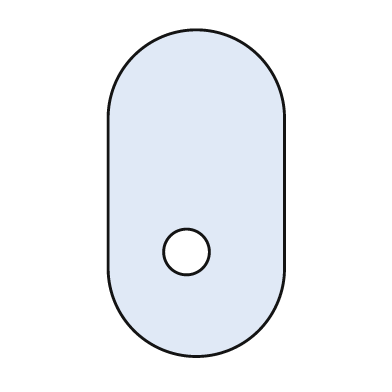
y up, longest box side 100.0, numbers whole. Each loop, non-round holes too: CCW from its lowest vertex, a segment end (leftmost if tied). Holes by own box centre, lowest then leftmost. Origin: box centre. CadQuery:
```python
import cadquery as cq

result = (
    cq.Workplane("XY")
    .moveTo(-27.0, -23.0)
    .threePointArc((0.0, -50.0), (27.0, -23.0))
    .lineTo(27.0, 23.0)
    .threePointArc((0.0, 50.0), (-27.0, 23.0))
    .close()
    .moveTo(-3.0, -18.0)
    .circle(7.0)
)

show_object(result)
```